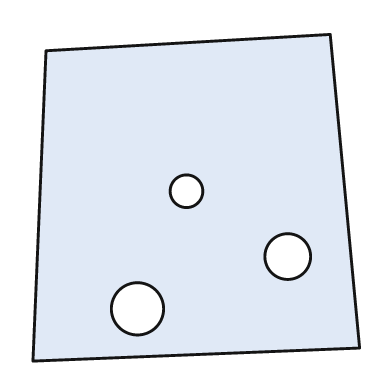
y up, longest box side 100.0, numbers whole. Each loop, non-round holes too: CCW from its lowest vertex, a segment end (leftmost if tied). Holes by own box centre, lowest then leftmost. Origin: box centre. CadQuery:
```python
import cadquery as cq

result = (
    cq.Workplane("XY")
    .moveTo(-50.0, -50.0)
    .lineTo(50.0, -46.0)
    .lineTo(41.0, 50.0)
    .lineTo(-46.0, 45.0)
    .close()
    .moveTo(-18.0, -34.0)
    .circle(8.0)
    .moveTo(28.0, -18.0)
    .circle(7.0)
    .moveTo(-3.0, 2.0)
    .circle(5.0)
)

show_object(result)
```